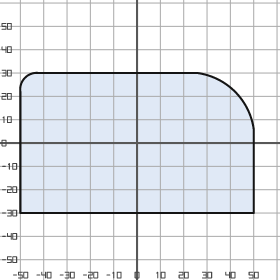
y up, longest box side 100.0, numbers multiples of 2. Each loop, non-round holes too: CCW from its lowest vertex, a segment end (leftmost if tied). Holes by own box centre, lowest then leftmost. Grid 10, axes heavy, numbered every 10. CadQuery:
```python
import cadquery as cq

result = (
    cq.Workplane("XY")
    .moveTo(-50.0, -30.0)
    .lineTo(50.0, -30.0)
    .lineTo(50.0, 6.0)
    .threePointArc((42.0, 22.0), (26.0, 30.0))
    .lineTo(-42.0, 30.0)
    .threePointArc((-48.0, 28.0), (-50.0, 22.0))
    .close()
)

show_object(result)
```